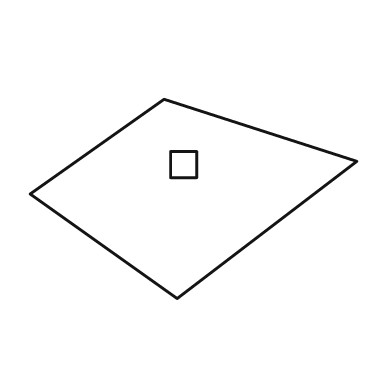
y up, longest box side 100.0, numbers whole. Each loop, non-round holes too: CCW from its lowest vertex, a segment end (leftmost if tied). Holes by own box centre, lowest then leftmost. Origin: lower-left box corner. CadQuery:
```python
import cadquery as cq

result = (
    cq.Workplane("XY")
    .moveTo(45.0, 0.0)
    .lineTo(100.0, 42.0)
    .lineTo(41.0, 61.0)
    .lineTo(0.0, 32.0)
    .close()
    .moveTo(43.0, 37.0)
    .lineTo(51.0, 37.0)
    .lineTo(51.0, 45.0)
    .lineTo(43.0, 45.0)
    .close()
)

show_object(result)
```